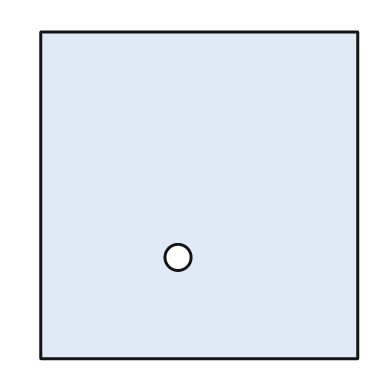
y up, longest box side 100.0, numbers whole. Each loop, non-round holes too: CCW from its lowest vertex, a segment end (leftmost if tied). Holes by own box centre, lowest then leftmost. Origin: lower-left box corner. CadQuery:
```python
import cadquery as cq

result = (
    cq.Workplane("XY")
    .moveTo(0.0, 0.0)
    .lineTo(97.0, 0.0)
    .lineTo(97.0, 100.0)
    .lineTo(0.0, 100.0)
    .close()
    .moveTo(42.0, 31.0)
    .circle(4.0)
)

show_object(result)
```